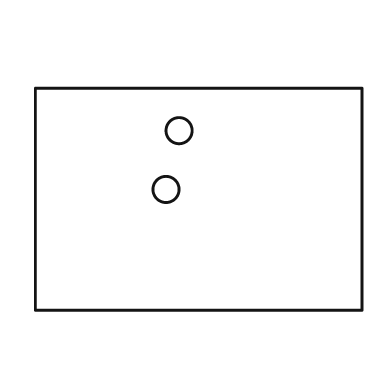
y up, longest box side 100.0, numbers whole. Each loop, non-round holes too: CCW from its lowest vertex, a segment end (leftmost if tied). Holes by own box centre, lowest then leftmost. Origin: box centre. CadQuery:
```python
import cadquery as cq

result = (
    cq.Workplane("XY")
    .moveTo(-50.0, -34.0)
    .lineTo(50.0, -34.0)
    .lineTo(50.0, 34.0)
    .lineTo(-50.0, 34.0)
    .close()
    .moveTo(-10.0, 3.0)
    .circle(4.0)
    .moveTo(-6.0, 21.0)
    .circle(4.0)
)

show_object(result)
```